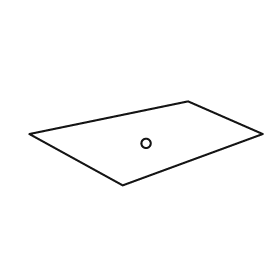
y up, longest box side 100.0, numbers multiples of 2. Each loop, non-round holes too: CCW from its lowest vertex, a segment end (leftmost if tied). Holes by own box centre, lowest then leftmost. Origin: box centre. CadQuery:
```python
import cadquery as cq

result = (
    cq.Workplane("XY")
    .moveTo(-10.0, -18.0)
    .lineTo(50.0, 4.0)
    .lineTo(18.0, 18.0)
    .lineTo(-50.0, 4.0)
    .close()
    .moveTo(0.0, 0.0)
    .circle(2.0)
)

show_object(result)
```